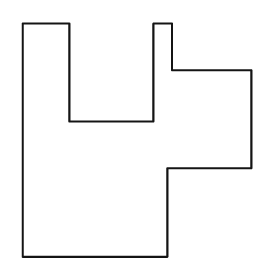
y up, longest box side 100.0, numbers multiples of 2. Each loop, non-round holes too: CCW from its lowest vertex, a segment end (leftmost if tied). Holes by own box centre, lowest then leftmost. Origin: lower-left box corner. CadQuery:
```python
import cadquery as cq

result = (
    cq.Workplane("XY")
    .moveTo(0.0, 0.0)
    .lineTo(62.0, 0.0)
    .lineTo(62.0, 38.0)
    .lineTo(98.0, 38.0)
    .lineTo(98.0, 80.0)
    .lineTo(64.0, 80.0)
    .lineTo(64.0, 100.0)
    .lineTo(56.0, 100.0)
    .lineTo(56.0, 58.0)
    .lineTo(20.0, 58.0)
    .lineTo(20.0, 100.0)
    .lineTo(0.0, 100.0)
    .close()
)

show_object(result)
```